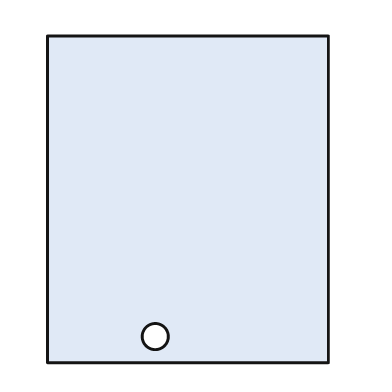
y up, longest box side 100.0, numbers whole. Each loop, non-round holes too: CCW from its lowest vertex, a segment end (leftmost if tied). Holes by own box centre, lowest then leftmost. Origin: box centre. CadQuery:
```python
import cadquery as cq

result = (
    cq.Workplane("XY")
    .moveTo(-43.0, -50.0)
    .lineTo(43.0, -50.0)
    .lineTo(43.0, 50.0)
    .lineTo(-43.0, 50.0)
    .close()
    .moveTo(-10.0, -42.0)
    .circle(4.0)
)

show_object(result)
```